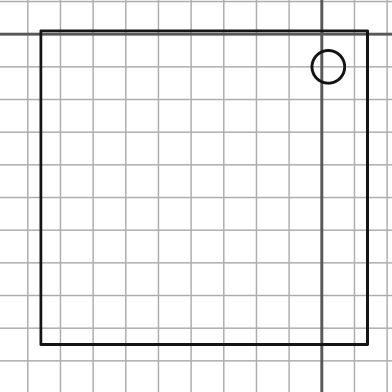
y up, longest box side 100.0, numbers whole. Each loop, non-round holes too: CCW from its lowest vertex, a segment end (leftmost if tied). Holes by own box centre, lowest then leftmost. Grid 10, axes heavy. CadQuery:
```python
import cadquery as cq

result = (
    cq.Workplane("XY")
    .moveTo(-86.0, -95.0)
    .lineTo(14.0, -95.0)
    .lineTo(14.0, 1.0)
    .lineTo(-86.0, 1.0)
    .close()
    .moveTo(2.0, -10.0)
    .circle(5.0)
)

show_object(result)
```